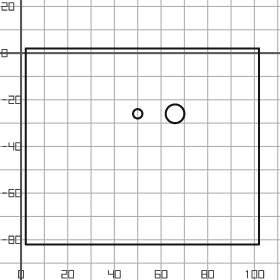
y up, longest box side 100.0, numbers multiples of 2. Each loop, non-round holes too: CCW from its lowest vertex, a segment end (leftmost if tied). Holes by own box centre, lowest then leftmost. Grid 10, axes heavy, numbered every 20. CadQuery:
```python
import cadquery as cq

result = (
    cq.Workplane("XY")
    .moveTo(2.0, -82.0)
    .lineTo(102.0, -82.0)
    .lineTo(102.0, 2.0)
    .lineTo(2.0, 2.0)
    .close()
    .moveTo(50.0, -26.0)
    .circle(2.0)
    .moveTo(66.0, -26.0)
    .circle(4.0)
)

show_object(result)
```